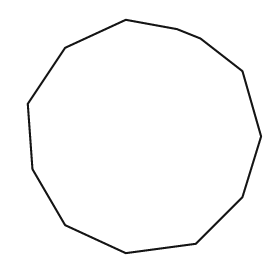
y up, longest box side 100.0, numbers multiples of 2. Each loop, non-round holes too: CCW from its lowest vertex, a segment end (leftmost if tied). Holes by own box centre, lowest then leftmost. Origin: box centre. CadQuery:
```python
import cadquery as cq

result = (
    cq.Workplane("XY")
    .moveTo(-8.0, -50.0)
    .lineTo(22.0, -46.0)
    .lineTo(42.0, -26.0)
    .lineTo(50.0, 0.0)
    .lineTo(42.0, 28.0)
    .lineTo(24.0, 42.0)
    .lineTo(14.0, 46.0)
    .lineTo(-8.0, 50.0)
    .lineTo(-34.0, 38.0)
    .lineTo(-50.0, 14.0)
    .lineTo(-48.0, -14.0)
    .lineTo(-34.0, -38.0)
    .close()
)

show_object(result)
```